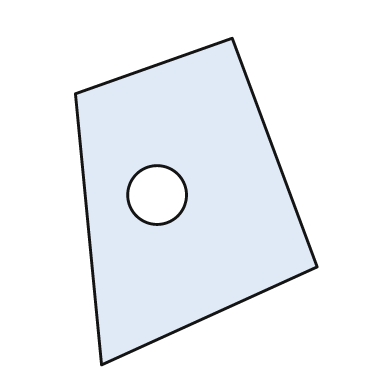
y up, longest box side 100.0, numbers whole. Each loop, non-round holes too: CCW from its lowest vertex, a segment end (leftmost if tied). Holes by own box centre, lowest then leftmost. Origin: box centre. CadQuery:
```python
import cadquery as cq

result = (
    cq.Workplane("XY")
    .moveTo(-29.0, -50.0)
    .lineTo(37.0, -20.0)
    .lineTo(11.0, 50.0)
    .lineTo(-37.0, 33.0)
    .close()
    .moveTo(-12.0, 2.0)
    .circle(9.0)
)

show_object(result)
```